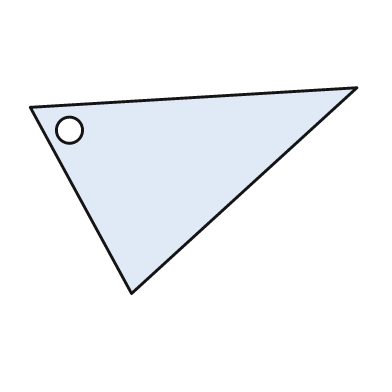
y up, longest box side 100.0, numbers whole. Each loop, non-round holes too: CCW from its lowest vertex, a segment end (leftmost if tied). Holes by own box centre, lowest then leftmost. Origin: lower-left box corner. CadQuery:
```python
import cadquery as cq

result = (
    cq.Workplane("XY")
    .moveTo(31.0, 0.0)
    .lineTo(100.0, 63.0)
    .lineTo(0.0, 57.0)
    .close()
    .moveTo(12.0, 50.0)
    .circle(4.0)
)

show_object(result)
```